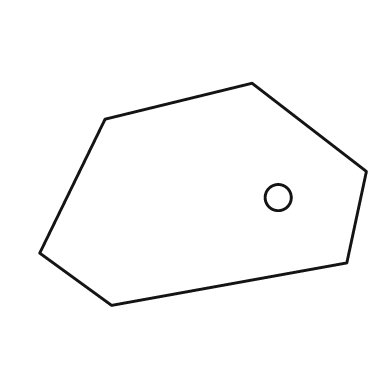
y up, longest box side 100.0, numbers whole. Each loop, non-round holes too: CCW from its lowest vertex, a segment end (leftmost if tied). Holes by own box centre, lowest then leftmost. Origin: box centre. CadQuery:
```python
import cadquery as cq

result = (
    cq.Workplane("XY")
    .moveTo(-28.0, -34.0)
    .lineTo(44.0, -21.0)
    .lineTo(50.0, 7.0)
    .lineTo(15.0, 34.0)
    .lineTo(-30.0, 23.0)
    .lineTo(-50.0, -18.0)
    .close()
    .moveTo(23.0, -1.0)
    .circle(4.0)
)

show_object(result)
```